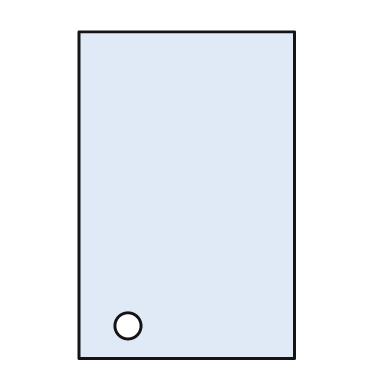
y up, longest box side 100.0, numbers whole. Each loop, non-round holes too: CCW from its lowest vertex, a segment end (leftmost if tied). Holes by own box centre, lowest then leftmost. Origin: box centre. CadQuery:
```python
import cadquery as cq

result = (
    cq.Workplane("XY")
    .moveTo(-33.0, -50.0)
    .lineTo(33.0, -50.0)
    .lineTo(33.0, 50.0)
    .lineTo(-33.0, 50.0)
    .close()
    .moveTo(-18.0, -40.0)
    .circle(4.0)
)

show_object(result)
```